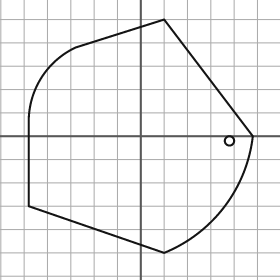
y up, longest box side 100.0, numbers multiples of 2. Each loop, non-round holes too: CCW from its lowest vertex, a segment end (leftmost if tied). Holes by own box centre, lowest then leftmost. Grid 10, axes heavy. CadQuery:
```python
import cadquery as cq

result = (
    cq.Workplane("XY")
    .moveTo(10.0, -50.0)
    .threePointArc((36.0, -30.0), (48.0, 0.0))
    .lineTo(10.0, 50.0)
    .lineTo(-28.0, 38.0)
    .threePointArc((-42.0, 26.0), (-48.0, 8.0))
    .lineTo(-48.0, -30.0)
    .close()
    .moveTo(38.0, -2.0)
    .circle(2.0)
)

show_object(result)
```